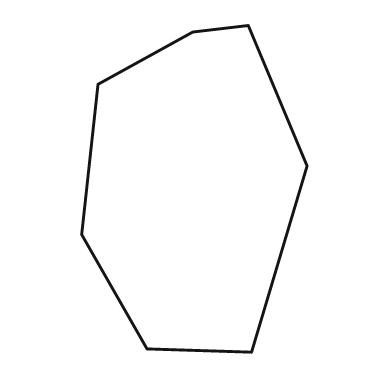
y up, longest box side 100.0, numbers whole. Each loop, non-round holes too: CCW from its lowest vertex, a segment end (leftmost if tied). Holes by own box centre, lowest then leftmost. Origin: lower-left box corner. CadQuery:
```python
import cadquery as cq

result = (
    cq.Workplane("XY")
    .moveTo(52.0, 0.0)
    .lineTo(69.0, 57.0)
    .lineTo(51.0, 100.0)
    .lineTo(34.0, 98.0)
    .lineTo(5.0, 82.0)
    .lineTo(0.0, 36.0)
    .lineTo(20.0, 1.0)
    .close()
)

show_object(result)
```